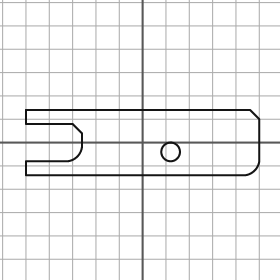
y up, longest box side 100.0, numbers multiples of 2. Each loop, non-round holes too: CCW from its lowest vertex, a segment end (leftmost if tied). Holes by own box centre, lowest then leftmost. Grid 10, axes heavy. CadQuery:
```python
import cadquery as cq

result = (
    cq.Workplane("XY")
    .moveTo(-50.0, -14.0)
    .lineTo(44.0, -14.0)
    .threePointArc((48.0, -12.0), (50.0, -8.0))
    .lineTo(50.0, 10.0)
    .lineTo(46.0, 14.0)
    .lineTo(-50.0, 14.0)
    .lineTo(-50.0, 8.0)
    .lineTo(-30.0, 8.0)
    .lineTo(-26.0, 4.0)
    .lineTo(-26.0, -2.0)
    .threePointArc((-28.0, -6.0), (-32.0, -8.0))
    .lineTo(-50.0, -8.0)
    .close()
    .moveTo(12.0, -4.0)
    .circle(4.0)
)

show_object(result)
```